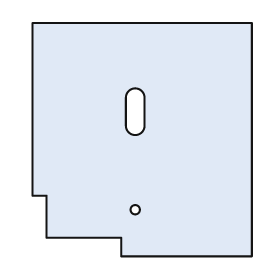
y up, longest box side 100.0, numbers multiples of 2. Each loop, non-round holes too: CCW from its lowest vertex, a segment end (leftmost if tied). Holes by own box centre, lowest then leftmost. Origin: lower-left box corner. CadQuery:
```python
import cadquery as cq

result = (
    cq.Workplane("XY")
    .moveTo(38.0, 0.0)
    .lineTo(94.0, 0.0)
    .lineTo(94.0, 100.0)
    .lineTo(0.0, 100.0)
    .lineTo(0.0, 26.0)
    .lineTo(6.0, 26.0)
    .lineTo(6.0, 8.0)
    .lineTo(38.0, 8.0)
    .close()
    .moveTo(44.0, 20.0)
    .circle(2.0)
    .moveTo(40.0, 56.0)
    .threePointArc((44.0, 52.0), (48.0, 56.0))
    .lineTo(48.0, 68.0)
    .threePointArc((44.0, 72.0), (40.0, 68.0))
    .close()
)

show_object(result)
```